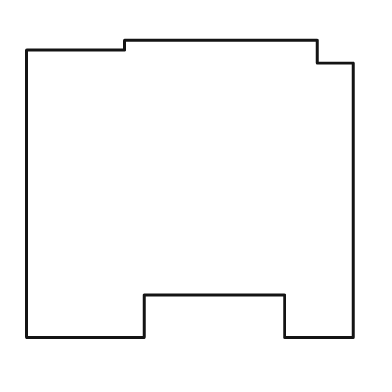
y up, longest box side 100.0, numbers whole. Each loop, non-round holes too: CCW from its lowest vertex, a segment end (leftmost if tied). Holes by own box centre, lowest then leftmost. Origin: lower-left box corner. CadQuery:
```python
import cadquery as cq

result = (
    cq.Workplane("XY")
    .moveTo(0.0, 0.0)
    .lineTo(36.0, 0.0)
    .lineTo(36.0, 13.0)
    .lineTo(79.0, 13.0)
    .lineTo(79.0, 0.0)
    .lineTo(100.0, 0.0)
    .lineTo(100.0, 84.0)
    .lineTo(89.0, 84.0)
    .lineTo(89.0, 91.0)
    .lineTo(30.0, 91.0)
    .lineTo(30.0, 88.0)
    .lineTo(0.0, 88.0)
    .close()
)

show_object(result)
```